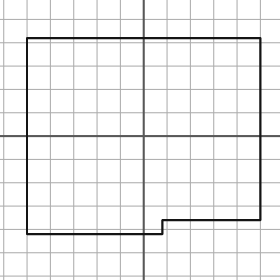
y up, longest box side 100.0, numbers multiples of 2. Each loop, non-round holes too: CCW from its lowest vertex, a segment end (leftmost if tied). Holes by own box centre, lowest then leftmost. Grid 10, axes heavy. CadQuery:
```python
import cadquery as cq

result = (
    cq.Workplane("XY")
    .moveTo(-50.0, -42.0)
    .lineTo(8.0, -42.0)
    .lineTo(8.0, -36.0)
    .lineTo(50.0, -36.0)
    .lineTo(50.0, 42.0)
    .lineTo(-50.0, 42.0)
    .close()
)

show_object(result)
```